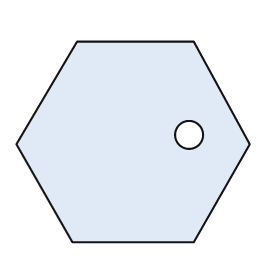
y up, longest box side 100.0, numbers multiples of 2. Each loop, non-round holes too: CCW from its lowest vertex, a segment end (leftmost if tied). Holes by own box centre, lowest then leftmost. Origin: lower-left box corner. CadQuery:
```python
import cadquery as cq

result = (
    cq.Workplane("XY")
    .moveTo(24.0, 0.0)
    .lineTo(76.0, 0.0)
    .lineTo(100.0, 42.0)
    .lineTo(76.0, 86.0)
    .lineTo(26.0, 86.0)
    .lineTo(0.0, 42.0)
    .close()
    .moveTo(74.0, 46.0)
    .circle(6.0)
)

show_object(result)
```